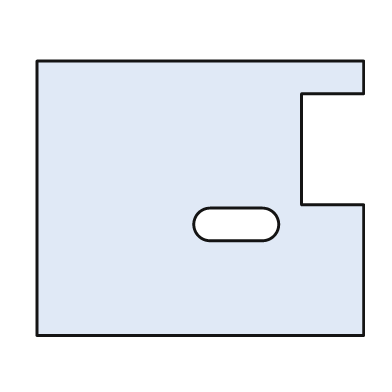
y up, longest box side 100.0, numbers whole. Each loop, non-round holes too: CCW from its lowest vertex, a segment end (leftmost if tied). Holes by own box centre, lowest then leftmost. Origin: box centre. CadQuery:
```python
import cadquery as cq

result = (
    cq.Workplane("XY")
    .moveTo(-50.0, -42.0)
    .lineTo(50.0, -42.0)
    .lineTo(50.0, -2.0)
    .lineTo(31.0, -2.0)
    .lineTo(31.0, 32.0)
    .lineTo(50.0, 32.0)
    .lineTo(50.0, 42.0)
    .lineTo(-50.0, 42.0)
    .close()
    .moveTo(3.0, -13.0)
    .lineTo(19.0, -13.0)
    .threePointArc((24.0, -8.0), (19.0, -3.0))
    .lineTo(3.0, -3.0)
    .threePointArc((-2.0, -8.0), (3.0, -13.0))
    .close()
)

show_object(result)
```